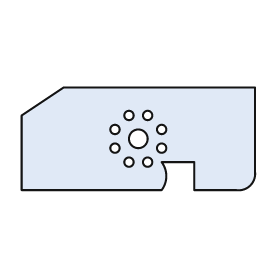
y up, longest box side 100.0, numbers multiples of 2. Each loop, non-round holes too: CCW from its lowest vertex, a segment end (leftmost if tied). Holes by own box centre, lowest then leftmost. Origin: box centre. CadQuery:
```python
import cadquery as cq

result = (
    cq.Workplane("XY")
    .moveTo(-50.0, -22.0)
    .lineTo(10.0, -22.0)
    .threePointArc((12.0, -16.0), (10.0, -10.0))
    .lineTo(24.0, -10.0)
    .lineTo(24.0, -22.0)
    .lineTo(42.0, -22.0)
    .threePointArc((48.0, -20.0), (50.0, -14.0))
    .lineTo(50.0, 22.0)
    .lineTo(-32.0, 22.0)
    .lineTo(-50.0, 10.0)
    .close()
    .moveTo(-4.0, -10.0)
    .circle(2.0)
    .moveTo(4.0, -10.0)
    .circle(2.0)
    .moveTo(-10.0, -4.0)
    .circle(2.0)
    .moveTo(10.0, -4.0)
    .circle(2.0)
    .moveTo(0.0, 0.0)
    .circle(4.0)
    .moveTo(-10.0, 4.0)
    .circle(2.0)
    .moveTo(10.0, 4.0)
    .circle(2.0)
    .moveTo(-4.0, 10.0)
    .circle(2.0)
    .moveTo(4.0, 10.0)
    .circle(2.0)
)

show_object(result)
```